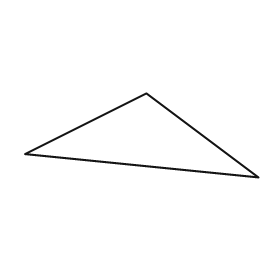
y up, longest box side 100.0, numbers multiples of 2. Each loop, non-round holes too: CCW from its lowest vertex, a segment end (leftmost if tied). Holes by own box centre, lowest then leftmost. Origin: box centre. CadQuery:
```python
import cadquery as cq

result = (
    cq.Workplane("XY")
    .moveTo(50.0, -18.0)
    .lineTo(2.0, 18.0)
    .lineTo(-50.0, -8.0)
    .close()
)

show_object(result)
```